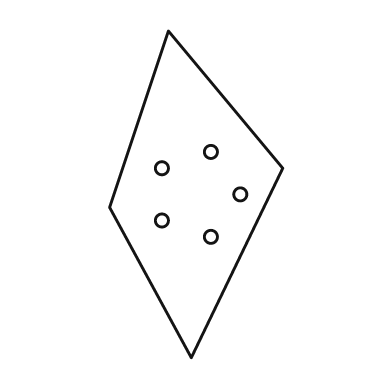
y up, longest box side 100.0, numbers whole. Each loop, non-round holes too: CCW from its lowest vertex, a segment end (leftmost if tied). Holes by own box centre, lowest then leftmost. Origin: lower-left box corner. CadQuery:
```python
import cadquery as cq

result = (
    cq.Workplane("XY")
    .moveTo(25.0, 0.0)
    .lineTo(53.0, 58.0)
    .lineTo(18.0, 100.0)
    .lineTo(0.0, 46.0)
    .close()
    .moveTo(31.0, 37.0)
    .circle(2.0)
    .moveTo(16.0, 42.0)
    .circle(2.0)
    .moveTo(40.0, 50.0)
    .circle(2.0)
    .moveTo(16.0, 58.0)
    .circle(2.0)
    .moveTo(31.0, 63.0)
    .circle(2.0)
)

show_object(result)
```